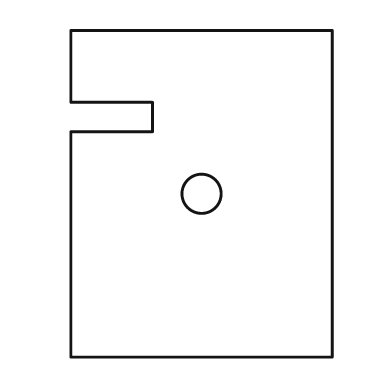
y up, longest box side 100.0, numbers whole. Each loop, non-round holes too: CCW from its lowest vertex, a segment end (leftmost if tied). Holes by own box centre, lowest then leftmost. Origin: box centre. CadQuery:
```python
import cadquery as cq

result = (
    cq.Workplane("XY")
    .moveTo(-40.0, -50.0)
    .lineTo(40.0, -50.0)
    .lineTo(40.0, 50.0)
    .lineTo(-40.0, 50.0)
    .lineTo(-40.0, 28.0)
    .lineTo(-15.0, 28.0)
    .lineTo(-15.0, 19.0)
    .lineTo(-40.0, 19.0)
    .close()
    .moveTo(0.0, 0.0)
    .circle(6.0)
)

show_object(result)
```